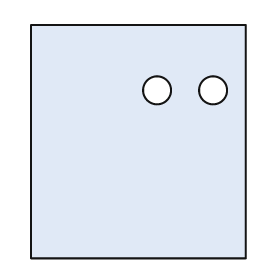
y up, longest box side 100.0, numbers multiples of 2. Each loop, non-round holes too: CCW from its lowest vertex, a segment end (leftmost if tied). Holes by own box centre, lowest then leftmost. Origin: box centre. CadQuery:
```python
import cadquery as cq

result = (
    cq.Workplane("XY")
    .moveTo(-46.0, -50.0)
    .lineTo(46.0, -50.0)
    .lineTo(46.0, 50.0)
    .lineTo(-46.0, 50.0)
    .close()
    .moveTo(8.0, 22.0)
    .circle(6.0)
    .moveTo(32.0, 22.0)
    .circle(6.0)
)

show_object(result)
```